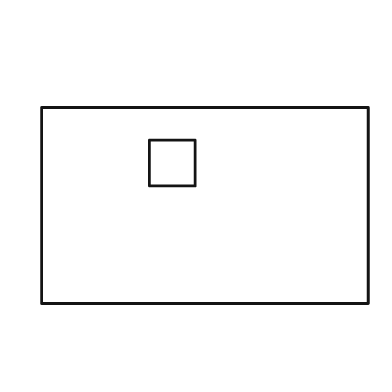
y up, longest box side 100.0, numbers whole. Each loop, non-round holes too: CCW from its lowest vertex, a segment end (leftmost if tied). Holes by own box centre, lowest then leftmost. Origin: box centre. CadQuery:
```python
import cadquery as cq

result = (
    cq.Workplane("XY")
    .moveTo(-50.0, -30.0)
    .lineTo(50.0, -30.0)
    .lineTo(50.0, 30.0)
    .lineTo(-50.0, 30.0)
    .close()
    .moveTo(-17.0, 6.0)
    .lineTo(-3.0, 6.0)
    .lineTo(-3.0, 20.0)
    .lineTo(-17.0, 20.0)
    .close()
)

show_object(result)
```